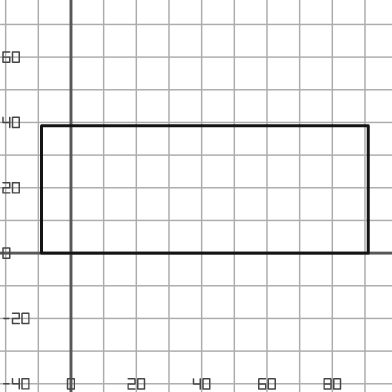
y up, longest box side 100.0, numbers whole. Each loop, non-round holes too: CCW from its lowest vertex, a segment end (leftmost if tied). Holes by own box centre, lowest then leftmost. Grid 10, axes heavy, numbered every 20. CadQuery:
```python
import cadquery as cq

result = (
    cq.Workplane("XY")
    .moveTo(-9.0, 0.0)
    .lineTo(91.0, 0.0)
    .lineTo(91.0, 39.0)
    .lineTo(-9.0, 39.0)
    .close()
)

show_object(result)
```